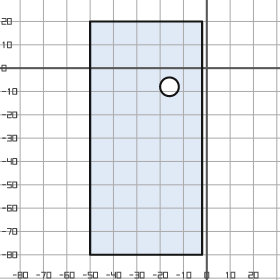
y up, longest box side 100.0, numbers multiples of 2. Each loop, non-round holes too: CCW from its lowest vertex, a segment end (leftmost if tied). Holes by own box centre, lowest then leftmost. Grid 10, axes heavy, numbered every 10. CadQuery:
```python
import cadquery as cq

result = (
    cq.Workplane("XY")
    .moveTo(-50.0, -80.0)
    .lineTo(-2.0, -80.0)
    .lineTo(-2.0, 20.0)
    .lineTo(-50.0, 20.0)
    .close()
    .moveTo(-16.0, -8.0)
    .circle(4.0)
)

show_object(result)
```